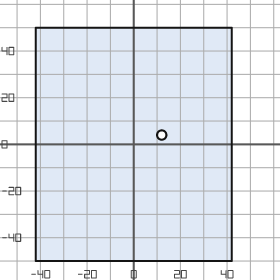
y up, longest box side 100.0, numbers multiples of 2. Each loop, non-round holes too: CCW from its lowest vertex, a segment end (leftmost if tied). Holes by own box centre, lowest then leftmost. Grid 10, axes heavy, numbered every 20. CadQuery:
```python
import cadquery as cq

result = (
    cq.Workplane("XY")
    .moveTo(-42.0, -50.0)
    .lineTo(42.0, -50.0)
    .lineTo(42.0, 50.0)
    .lineTo(-42.0, 50.0)
    .close()
    .moveTo(12.0, 4.0)
    .circle(2.0)
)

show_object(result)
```